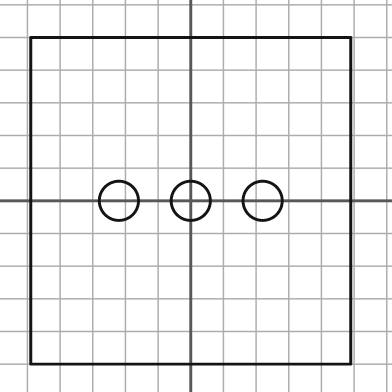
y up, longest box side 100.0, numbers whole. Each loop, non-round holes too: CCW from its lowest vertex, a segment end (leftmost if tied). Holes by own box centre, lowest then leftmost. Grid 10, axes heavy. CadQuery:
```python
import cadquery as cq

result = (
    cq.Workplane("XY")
    .moveTo(-49.0, -50.0)
    .lineTo(49.0, -50.0)
    .lineTo(49.0, 50.0)
    .lineTo(-49.0, 50.0)
    .close()
    .moveTo(-22.0, 0.0)
    .circle(6.0)
    .moveTo(0.0, 0.0)
    .circle(6.0)
    .moveTo(22.0, 0.0)
    .circle(6.0)
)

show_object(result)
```